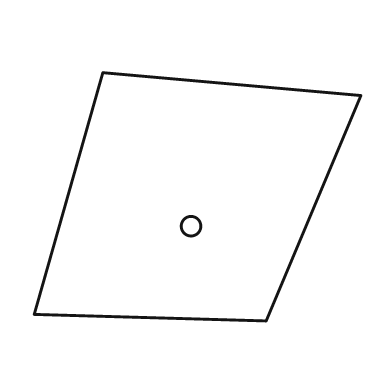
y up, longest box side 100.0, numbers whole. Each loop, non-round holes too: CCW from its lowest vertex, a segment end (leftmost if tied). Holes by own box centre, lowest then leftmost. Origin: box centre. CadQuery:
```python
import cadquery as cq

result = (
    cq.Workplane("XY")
    .moveTo(21.0, -38.0)
    .lineTo(50.0, 31.0)
    .lineTo(-29.0, 38.0)
    .lineTo(-50.0, -36.0)
    .close()
    .moveTo(-2.0, -9.0)
    .circle(3.0)
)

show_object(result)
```